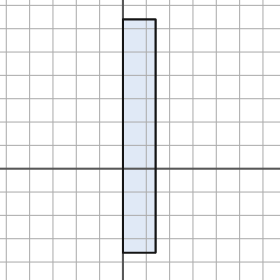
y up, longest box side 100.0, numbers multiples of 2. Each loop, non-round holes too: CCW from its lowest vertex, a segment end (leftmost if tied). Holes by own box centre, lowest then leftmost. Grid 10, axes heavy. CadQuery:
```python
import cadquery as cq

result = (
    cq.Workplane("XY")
    .moveTo(0.0, -36.0)
    .lineTo(14.0, -36.0)
    .lineTo(14.0, 64.0)
    .lineTo(0.0, 64.0)
    .close()
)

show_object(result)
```